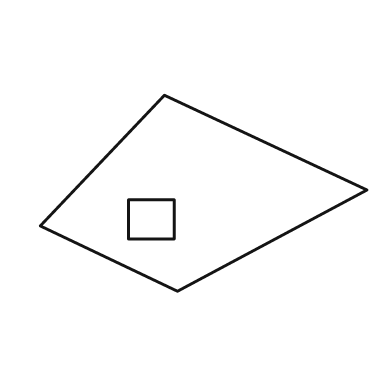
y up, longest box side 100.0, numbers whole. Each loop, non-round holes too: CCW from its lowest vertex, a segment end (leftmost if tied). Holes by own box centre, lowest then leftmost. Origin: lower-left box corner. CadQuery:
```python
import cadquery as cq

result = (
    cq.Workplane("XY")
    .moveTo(42.0, 0.0)
    .lineTo(100.0, 31.0)
    .lineTo(38.0, 60.0)
    .lineTo(0.0, 20.0)
    .close()
    .moveTo(27.0, 16.0)
    .lineTo(41.0, 16.0)
    .lineTo(41.0, 28.0)
    .lineTo(27.0, 28.0)
    .close()
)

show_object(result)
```